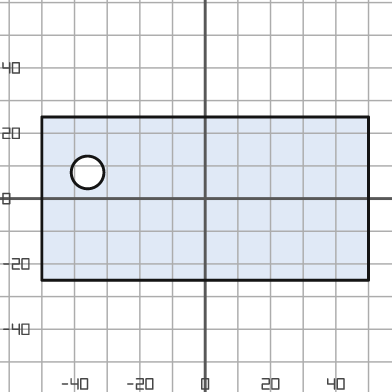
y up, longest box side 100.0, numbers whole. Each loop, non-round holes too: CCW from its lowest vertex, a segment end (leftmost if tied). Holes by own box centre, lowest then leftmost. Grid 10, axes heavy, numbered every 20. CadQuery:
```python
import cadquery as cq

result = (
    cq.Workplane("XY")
    .moveTo(-50.0, -25.0)
    .lineTo(50.0, -25.0)
    .lineTo(50.0, 25.0)
    .lineTo(-50.0, 25.0)
    .close()
    .moveTo(-36.0, 8.0)
    .circle(5.0)
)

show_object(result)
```